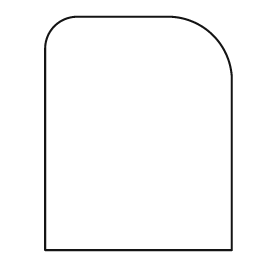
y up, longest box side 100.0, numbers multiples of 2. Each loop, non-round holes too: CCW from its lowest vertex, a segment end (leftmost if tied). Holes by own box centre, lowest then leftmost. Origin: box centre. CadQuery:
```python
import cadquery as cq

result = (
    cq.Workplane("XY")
    .moveTo(-40.0, -50.0)
    .lineTo(40.0, -50.0)
    .lineTo(40.0, 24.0)
    .threePointArc((32.0, 42.0), (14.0, 50.0))
    .lineTo(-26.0, 50.0)
    .threePointArc((-36.0, 46.0), (-40.0, 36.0))
    .close()
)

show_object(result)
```